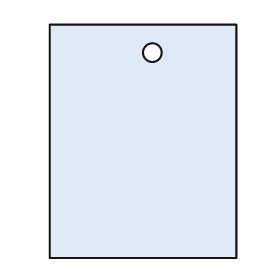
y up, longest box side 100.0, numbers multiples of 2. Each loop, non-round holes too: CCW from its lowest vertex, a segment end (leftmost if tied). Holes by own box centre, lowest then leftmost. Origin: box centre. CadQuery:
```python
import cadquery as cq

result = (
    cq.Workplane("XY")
    .moveTo(-40.0, -50.0)
    .lineTo(40.0, -50.0)
    .lineTo(40.0, 50.0)
    .lineTo(-40.0, 50.0)
    .close()
    .moveTo(4.0, 38.0)
    .circle(4.0)
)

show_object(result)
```